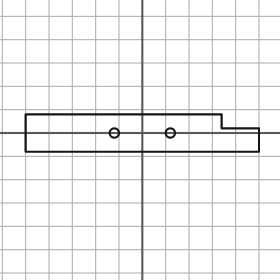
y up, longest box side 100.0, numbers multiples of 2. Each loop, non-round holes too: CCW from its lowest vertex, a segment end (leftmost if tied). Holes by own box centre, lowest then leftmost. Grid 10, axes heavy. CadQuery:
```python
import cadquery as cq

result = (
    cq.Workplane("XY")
    .moveTo(-50.0, -8.0)
    .lineTo(50.0, -8.0)
    .lineTo(50.0, 2.0)
    .lineTo(34.0, 2.0)
    .lineTo(34.0, 8.0)
    .lineTo(-50.0, 8.0)
    .close()
    .moveTo(-12.0, 0.0)
    .circle(2.0)
    .moveTo(12.0, 0.0)
    .circle(2.0)
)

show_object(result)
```